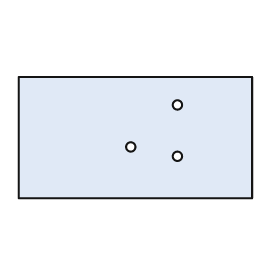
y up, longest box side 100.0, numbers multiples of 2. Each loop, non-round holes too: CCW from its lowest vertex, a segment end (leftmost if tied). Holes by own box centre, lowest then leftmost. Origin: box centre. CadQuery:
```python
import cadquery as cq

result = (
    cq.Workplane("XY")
    .moveTo(-50.0, -26.0)
    .lineTo(50.0, -26.0)
    .lineTo(50.0, 26.0)
    .lineTo(-50.0, 26.0)
    .close()
    .moveTo(18.0, -8.0)
    .circle(2.0)
    .moveTo(-2.0, -4.0)
    .circle(2.0)
    .moveTo(18.0, 14.0)
    .circle(2.0)
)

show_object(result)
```